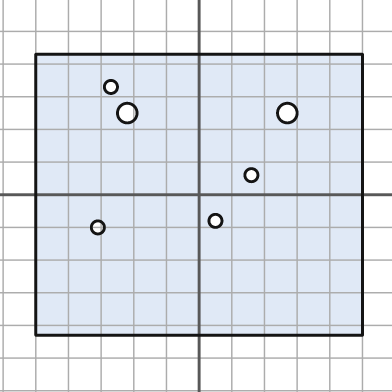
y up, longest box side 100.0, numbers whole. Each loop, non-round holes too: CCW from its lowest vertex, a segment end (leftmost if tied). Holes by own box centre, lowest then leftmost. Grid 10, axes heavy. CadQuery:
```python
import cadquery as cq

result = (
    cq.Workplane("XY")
    .moveTo(-50.0, -43.0)
    .lineTo(50.0, -43.0)
    .lineTo(50.0, 43.0)
    .lineTo(-50.0, 43.0)
    .close()
    .moveTo(-31.0, -10.0)
    .circle(2.0)
    .moveTo(5.0, -8.0)
    .circle(2.0)
    .moveTo(16.0, 6.0)
    .circle(2.0)
    .moveTo(-22.0, 25.0)
    .circle(3.0)
    .moveTo(27.0, 25.0)
    .circle(3.0)
    .moveTo(-27.0, 33.0)
    .circle(2.0)
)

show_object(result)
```